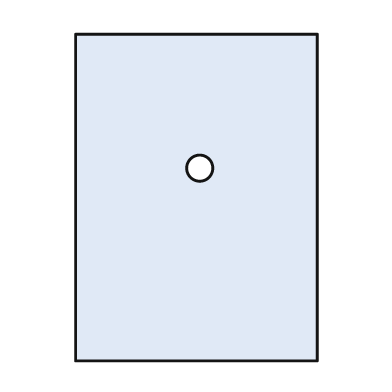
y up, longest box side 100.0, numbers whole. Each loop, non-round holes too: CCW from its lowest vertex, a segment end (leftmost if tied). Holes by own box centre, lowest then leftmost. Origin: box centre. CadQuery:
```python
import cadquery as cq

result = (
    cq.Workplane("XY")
    .moveTo(-37.0, -50.0)
    .lineTo(37.0, -50.0)
    .lineTo(37.0, 50.0)
    .lineTo(-37.0, 50.0)
    .close()
    .moveTo(1.0, 9.0)
    .circle(4.0)
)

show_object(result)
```